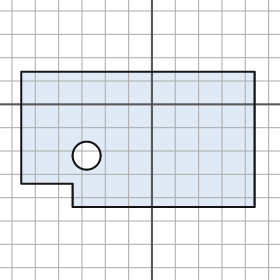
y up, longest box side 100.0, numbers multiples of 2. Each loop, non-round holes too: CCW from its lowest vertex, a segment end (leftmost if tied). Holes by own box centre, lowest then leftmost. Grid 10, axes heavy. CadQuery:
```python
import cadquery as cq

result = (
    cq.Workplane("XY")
    .moveTo(-34.0, -44.0)
    .lineTo(44.0, -44.0)
    .lineTo(44.0, 14.0)
    .lineTo(-56.0, 14.0)
    .lineTo(-56.0, -34.0)
    .lineTo(-34.0, -34.0)
    .close()
    .moveTo(-28.0, -22.0)
    .circle(6.0)
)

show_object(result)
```